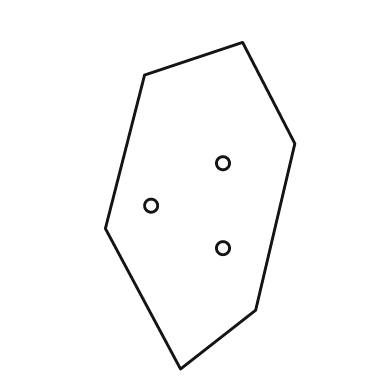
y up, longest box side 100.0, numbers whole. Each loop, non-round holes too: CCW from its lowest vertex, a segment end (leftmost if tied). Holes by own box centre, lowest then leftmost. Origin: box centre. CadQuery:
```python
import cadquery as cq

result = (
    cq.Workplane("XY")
    .moveTo(-6.0, -50.0)
    .lineTo(17.0, -32.0)
    .lineTo(29.0, 19.0)
    .lineTo(13.0, 50.0)
    .lineTo(-17.0, 40.0)
    .lineTo(-29.0, -7.0)
    .close()
    .moveTo(7.0, -13.0)
    .circle(2.0)
    .moveTo(-15.0, 0.0)
    .circle(2.0)
    .moveTo(7.0, 13.0)
    .circle(2.0)
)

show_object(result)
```